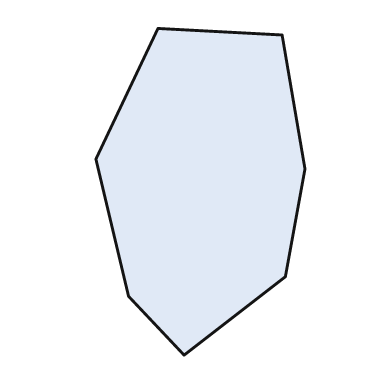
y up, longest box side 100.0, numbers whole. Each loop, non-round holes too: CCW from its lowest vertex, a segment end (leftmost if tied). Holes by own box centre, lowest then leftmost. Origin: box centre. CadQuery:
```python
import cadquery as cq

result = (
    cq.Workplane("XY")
    .moveTo(-5.0, -50.0)
    .lineTo(26.0, -26.0)
    .lineTo(32.0, 7.0)
    .lineTo(25.0, 48.0)
    .lineTo(-13.0, 50.0)
    .lineTo(-32.0, 10.0)
    .lineTo(-22.0, -32.0)
    .close()
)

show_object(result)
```